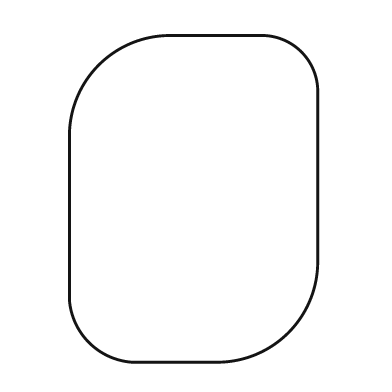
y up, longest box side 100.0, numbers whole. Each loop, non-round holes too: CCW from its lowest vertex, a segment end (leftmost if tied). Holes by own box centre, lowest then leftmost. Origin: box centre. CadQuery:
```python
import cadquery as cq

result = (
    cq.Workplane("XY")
    .moveTo(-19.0, -50.0)
    .lineTo(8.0, -50.0)
    .threePointArc((29.0, -41.0), (38.0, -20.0))
    .lineTo(38.0, 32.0)
    .threePointArc((33.0, 45.0), (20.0, 50.0))
    .lineTo(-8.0, 50.0)
    .threePointArc((-29.0, 41.0), (-38.0, 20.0))
    .lineTo(-38.0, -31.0)
    .threePointArc((-32.0, -44.0), (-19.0, -50.0))
    .close()
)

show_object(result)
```